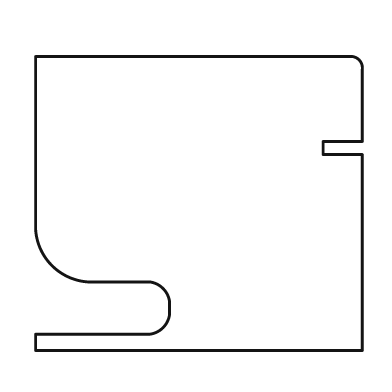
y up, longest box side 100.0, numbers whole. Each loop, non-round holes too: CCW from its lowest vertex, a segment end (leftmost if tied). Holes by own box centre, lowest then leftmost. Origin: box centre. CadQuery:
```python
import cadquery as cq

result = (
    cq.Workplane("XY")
    .moveTo(-50.0, -45.0)
    .lineTo(50.0, -45.0)
    .lineTo(50.0, 15.0)
    .lineTo(38.0, 15.0)
    .lineTo(38.0, 19.0)
    .lineTo(50.0, 19.0)
    .lineTo(50.0, 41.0)
    .threePointArc((49.0, 44.0), (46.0, 45.0))
    .lineTo(-50.0, 45.0)
    .lineTo(-50.0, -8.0)
    .threePointArc((-45.0, -19.0), (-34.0, -24.0))
    .lineTo(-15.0, -24.0)
    .threePointArc((-11.0, -26.0), (-9.0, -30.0))
    .lineTo(-9.0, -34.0)
    .threePointArc((-11.0, -38.0), (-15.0, -40.0))
    .lineTo(-50.0, -40.0)
    .close()
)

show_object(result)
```